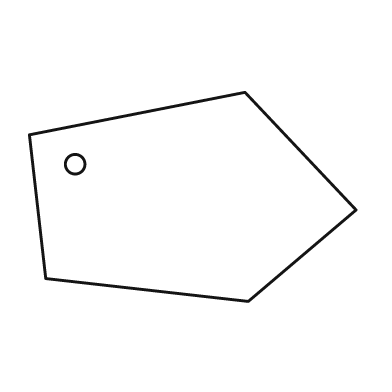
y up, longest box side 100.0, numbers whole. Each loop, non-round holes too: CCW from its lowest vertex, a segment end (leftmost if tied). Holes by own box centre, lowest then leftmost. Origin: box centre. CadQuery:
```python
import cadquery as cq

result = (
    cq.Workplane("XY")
    .moveTo(17.0, -32.0)
    .lineTo(50.0, -4.0)
    .lineTo(16.0, 32.0)
    .lineTo(-50.0, 19.0)
    .lineTo(-45.0, -25.0)
    .close()
    .moveTo(-36.0, 10.0)
    .circle(3.0)
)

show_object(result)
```